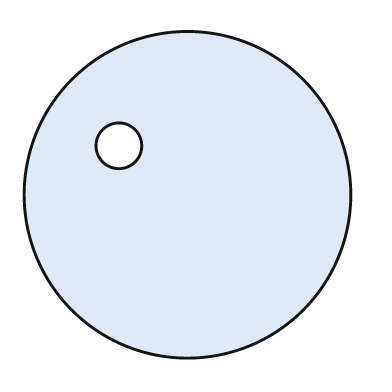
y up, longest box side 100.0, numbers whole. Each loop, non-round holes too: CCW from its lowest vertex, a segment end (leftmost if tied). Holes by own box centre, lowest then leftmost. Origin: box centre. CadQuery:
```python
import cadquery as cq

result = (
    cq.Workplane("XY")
    .moveTo(0.0, 0.0)
    .circle(50.0)
    .moveTo(-21.0, 15.0)
    .circle(7.0)
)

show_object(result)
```